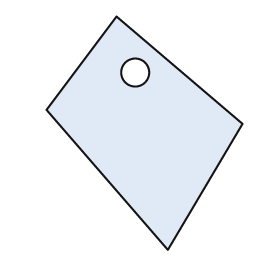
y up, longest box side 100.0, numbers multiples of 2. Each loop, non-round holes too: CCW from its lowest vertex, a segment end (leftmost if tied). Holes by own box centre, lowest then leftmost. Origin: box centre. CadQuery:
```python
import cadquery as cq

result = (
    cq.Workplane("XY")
    .moveTo(10.0, -50.0)
    .lineTo(42.0, 4.0)
    .lineTo(-12.0, 50.0)
    .lineTo(-42.0, 10.0)
    .close()
    .moveTo(-4.0, 26.0)
    .circle(6.0)
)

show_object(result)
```